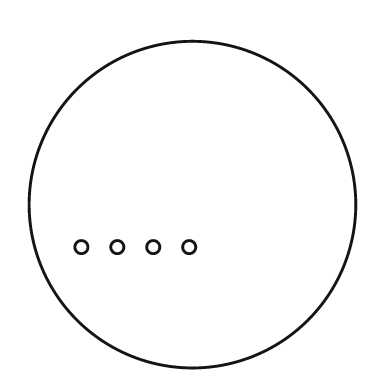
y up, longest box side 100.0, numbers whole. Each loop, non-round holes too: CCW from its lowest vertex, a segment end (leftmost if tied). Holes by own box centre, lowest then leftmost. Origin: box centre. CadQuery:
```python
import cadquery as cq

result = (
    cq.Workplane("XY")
    .moveTo(0.0, 0.0)
    .circle(50.0)
    .moveTo(-34.0, -13.0)
    .circle(2.0)
    .moveTo(-23.0, -13.0)
    .circle(2.0)
    .moveTo(-12.0, -13.0)
    .circle(2.0)
    .moveTo(-1.0, -13.0)
    .circle(2.0)
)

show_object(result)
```